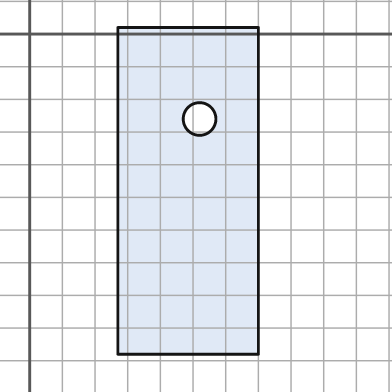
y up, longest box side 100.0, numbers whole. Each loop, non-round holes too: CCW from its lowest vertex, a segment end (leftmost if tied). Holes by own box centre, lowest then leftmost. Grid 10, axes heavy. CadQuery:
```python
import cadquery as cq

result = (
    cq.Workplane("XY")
    .moveTo(27.0, -98.0)
    .lineTo(70.0, -98.0)
    .lineTo(70.0, 2.0)
    .lineTo(27.0, 2.0)
    .close()
    .moveTo(52.0, -26.0)
    .circle(5.0)
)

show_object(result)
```